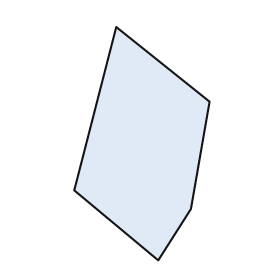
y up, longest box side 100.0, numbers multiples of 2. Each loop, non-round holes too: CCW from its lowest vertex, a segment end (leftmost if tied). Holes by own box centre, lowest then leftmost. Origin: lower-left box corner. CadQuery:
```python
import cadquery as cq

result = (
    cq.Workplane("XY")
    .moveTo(36.0, 0.0)
    .lineTo(50.0, 22.0)
    .lineTo(58.0, 68.0)
    .lineTo(18.0, 100.0)
    .lineTo(0.0, 30.0)
    .close()
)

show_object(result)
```